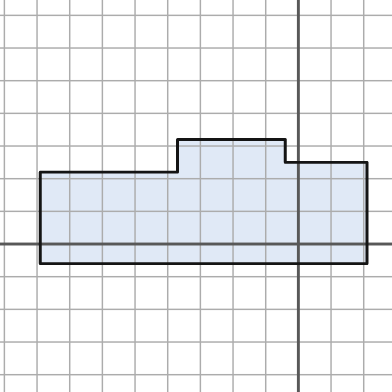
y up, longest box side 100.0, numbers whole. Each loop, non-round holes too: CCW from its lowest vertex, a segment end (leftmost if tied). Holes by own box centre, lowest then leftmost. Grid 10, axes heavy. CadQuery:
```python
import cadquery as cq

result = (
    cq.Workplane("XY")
    .moveTo(-79.0, -6.0)
    .lineTo(21.0, -6.0)
    .lineTo(21.0, 25.0)
    .lineTo(-4.0, 25.0)
    .lineTo(-4.0, 32.0)
    .lineTo(-37.0, 32.0)
    .lineTo(-37.0, 22.0)
    .lineTo(-79.0, 22.0)
    .close()
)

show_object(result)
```